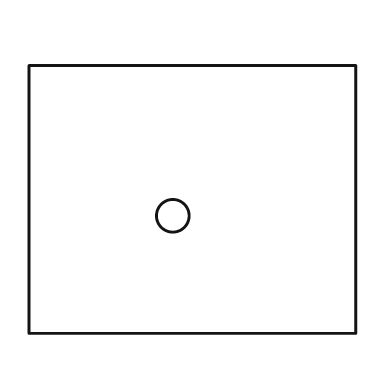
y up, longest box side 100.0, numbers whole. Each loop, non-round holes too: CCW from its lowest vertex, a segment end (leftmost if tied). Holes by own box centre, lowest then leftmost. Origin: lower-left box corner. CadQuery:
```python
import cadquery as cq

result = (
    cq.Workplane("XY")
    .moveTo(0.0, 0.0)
    .lineTo(100.0, 0.0)
    .lineTo(100.0, 82.0)
    .lineTo(0.0, 82.0)
    .close()
    .moveTo(44.0, 36.0)
    .circle(5.0)
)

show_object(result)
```